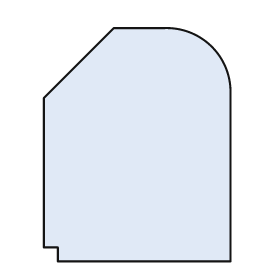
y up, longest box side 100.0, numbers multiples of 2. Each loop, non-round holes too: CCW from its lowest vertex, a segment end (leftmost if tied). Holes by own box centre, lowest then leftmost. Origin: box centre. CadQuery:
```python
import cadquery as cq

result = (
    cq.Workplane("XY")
    .moveTo(-34.0, -50.0)
    .lineTo(40.0, -50.0)
    .lineTo(40.0, 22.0)
    .threePointArc((32.0, 42.0), (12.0, 50.0))
    .lineTo(-10.0, 50.0)
    .lineTo(-40.0, 20.0)
    .lineTo(-40.0, -44.0)
    .lineTo(-34.0, -44.0)
    .close()
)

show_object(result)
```